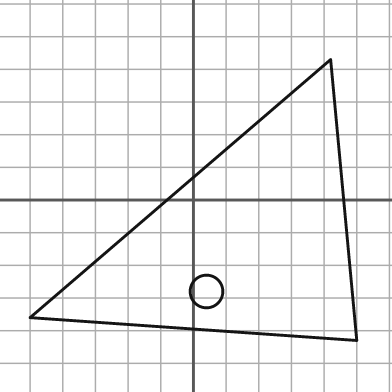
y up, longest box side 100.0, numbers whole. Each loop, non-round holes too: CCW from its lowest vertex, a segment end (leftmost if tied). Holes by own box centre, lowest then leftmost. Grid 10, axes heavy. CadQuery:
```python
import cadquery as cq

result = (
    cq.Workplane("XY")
    .moveTo(50.0, -43.0)
    .lineTo(42.0, 43.0)
    .lineTo(-50.0, -36.0)
    .close()
    .moveTo(4.0, -28.0)
    .circle(5.0)
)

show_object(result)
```